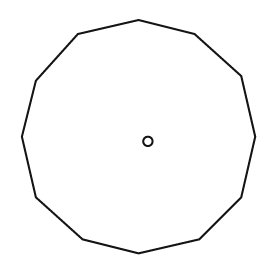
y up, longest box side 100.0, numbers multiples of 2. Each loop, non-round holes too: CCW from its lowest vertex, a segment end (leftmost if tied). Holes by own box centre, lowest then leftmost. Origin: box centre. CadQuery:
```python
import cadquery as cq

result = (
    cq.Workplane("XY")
    .moveTo(0.0, -50.0)
    .lineTo(26.0, -44.0)
    .lineTo(44.0, -26.0)
    .lineTo(50.0, 0.0)
    .lineTo(44.0, 26.0)
    .lineTo(24.0, 44.0)
    .lineTo(0.0, 50.0)
    .lineTo(-26.0, 44.0)
    .lineTo(-44.0, 24.0)
    .lineTo(-50.0, 0.0)
    .lineTo(-44.0, -26.0)
    .lineTo(-24.0, -44.0)
    .close()
    .moveTo(4.0, -2.0)
    .circle(2.0)
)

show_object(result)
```